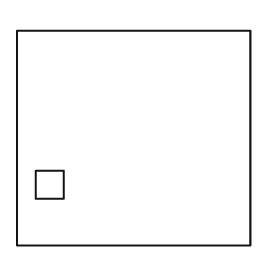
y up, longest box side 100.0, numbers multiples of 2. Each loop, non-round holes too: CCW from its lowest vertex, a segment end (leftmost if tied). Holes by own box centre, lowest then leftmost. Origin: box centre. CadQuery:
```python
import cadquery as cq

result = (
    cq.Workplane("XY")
    .moveTo(-50.0, -46.0)
    .lineTo(50.0, -46.0)
    .lineTo(50.0, 46.0)
    .lineTo(-50.0, 46.0)
    .close()
    .moveTo(-42.0, -26.0)
    .lineTo(-30.0, -26.0)
    .lineTo(-30.0, -14.0)
    .lineTo(-42.0, -14.0)
    .close()
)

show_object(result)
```